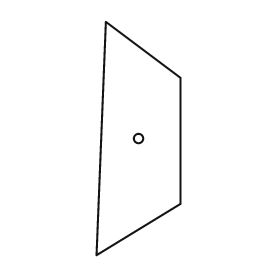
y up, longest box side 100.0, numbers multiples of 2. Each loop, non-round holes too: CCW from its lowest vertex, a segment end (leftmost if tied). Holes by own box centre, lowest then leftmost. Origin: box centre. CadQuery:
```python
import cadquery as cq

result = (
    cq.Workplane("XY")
    .moveTo(-18.0, -50.0)
    .lineTo(18.0, -28.0)
    .lineTo(18.0, 26.0)
    .lineTo(-14.0, 50.0)
    .close()
    .moveTo(0.0, 0.0)
    .circle(2.0)
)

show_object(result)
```